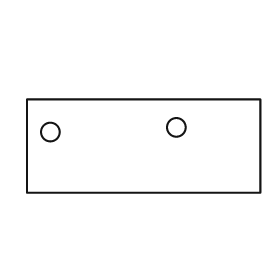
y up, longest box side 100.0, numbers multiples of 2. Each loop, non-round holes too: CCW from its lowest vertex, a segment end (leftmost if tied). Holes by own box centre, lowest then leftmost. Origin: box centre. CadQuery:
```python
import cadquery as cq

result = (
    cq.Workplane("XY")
    .moveTo(-50.0, -20.0)
    .lineTo(50.0, -20.0)
    .lineTo(50.0, 20.0)
    .lineTo(-50.0, 20.0)
    .close()
    .moveTo(-40.0, 6.0)
    .circle(4.0)
    .moveTo(14.0, 8.0)
    .circle(4.0)
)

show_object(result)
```